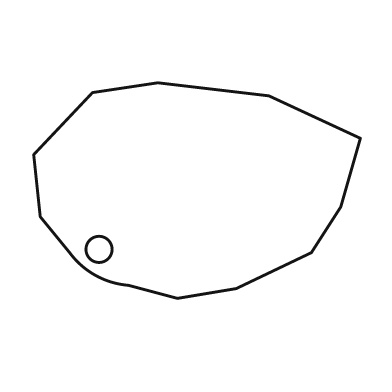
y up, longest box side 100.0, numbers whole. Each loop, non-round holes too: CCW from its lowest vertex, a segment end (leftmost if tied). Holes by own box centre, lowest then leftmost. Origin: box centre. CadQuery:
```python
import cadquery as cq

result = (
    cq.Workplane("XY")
    .moveTo(-6.0, -33.0)
    .lineTo(12.0, -30.0)
    .lineTo(35.0, -19.0)
    .lineTo(44.0, -5.0)
    .lineTo(50.0, 16.0)
    .lineTo(22.0, 29.0)
    .lineTo(-12.0, 33.0)
    .lineTo(-32.0, 30.0)
    .lineTo(-50.0, 11.0)
    .lineTo(-48.0, -8.0)
    .lineTo(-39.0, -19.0)
    .threePointArc((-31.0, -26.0), (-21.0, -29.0))
    .close()
    .moveTo(-30.0, -18.0)
    .circle(4.0)
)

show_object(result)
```